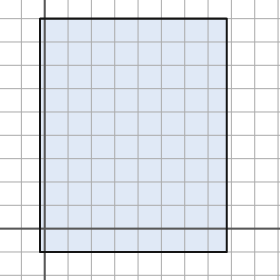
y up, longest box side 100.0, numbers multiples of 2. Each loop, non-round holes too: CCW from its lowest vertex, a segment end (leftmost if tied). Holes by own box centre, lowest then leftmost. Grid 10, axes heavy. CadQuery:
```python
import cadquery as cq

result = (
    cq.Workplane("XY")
    .moveTo(-2.0, -10.0)
    .lineTo(78.0, -10.0)
    .lineTo(78.0, 90.0)
    .lineTo(-2.0, 90.0)
    .close()
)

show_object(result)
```